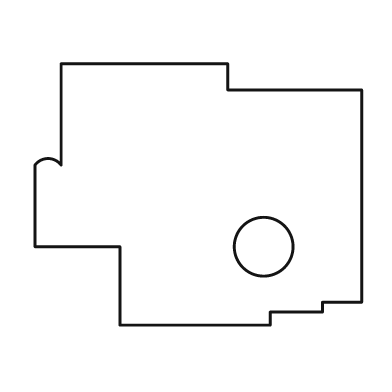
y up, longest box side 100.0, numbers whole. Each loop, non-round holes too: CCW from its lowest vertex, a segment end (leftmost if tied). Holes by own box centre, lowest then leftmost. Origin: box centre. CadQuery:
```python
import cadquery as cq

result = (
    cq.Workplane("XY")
    .moveTo(-24.0, -40.0)
    .lineTo(22.0, -40.0)
    .lineTo(22.0, -36.0)
    .lineTo(38.0, -36.0)
    .lineTo(38.0, -33.0)
    .lineTo(50.0, -33.0)
    .lineTo(50.0, 32.0)
    .lineTo(9.0, 32.0)
    .lineTo(9.0, 40.0)
    .lineTo(-42.0, 40.0)
    .lineTo(-42.0, 9.0)
    .threePointArc((-46.0, 11.0), (-50.0, 9.0))
    .lineTo(-50.0, -16.0)
    .lineTo(-24.0, -16.0)
    .close()
    .moveTo(20.0, -16.0)
    .circle(9.0)
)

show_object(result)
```